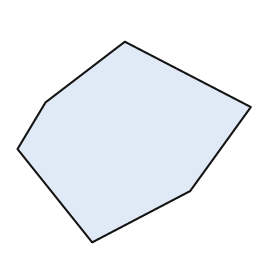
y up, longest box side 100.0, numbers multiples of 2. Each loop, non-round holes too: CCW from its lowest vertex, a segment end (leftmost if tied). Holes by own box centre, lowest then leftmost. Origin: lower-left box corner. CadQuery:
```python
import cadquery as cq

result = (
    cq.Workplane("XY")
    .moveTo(32.0, 0.0)
    .lineTo(74.0, 22.0)
    .lineTo(100.0, 58.0)
    .lineTo(46.0, 86.0)
    .lineTo(12.0, 60.0)
    .lineTo(0.0, 40.0)
    .close()
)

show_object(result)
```